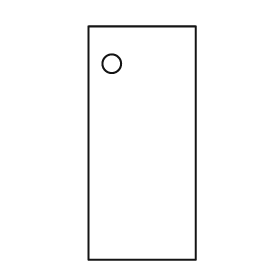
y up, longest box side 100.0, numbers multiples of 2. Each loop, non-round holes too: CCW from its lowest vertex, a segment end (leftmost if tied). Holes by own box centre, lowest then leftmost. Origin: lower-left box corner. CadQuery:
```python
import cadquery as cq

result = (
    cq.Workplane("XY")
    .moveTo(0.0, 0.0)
    .lineTo(46.0, 0.0)
    .lineTo(46.0, 100.0)
    .lineTo(0.0, 100.0)
    .close()
    .moveTo(10.0, 84.0)
    .circle(4.0)
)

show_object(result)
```